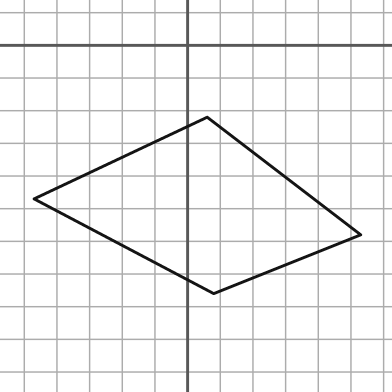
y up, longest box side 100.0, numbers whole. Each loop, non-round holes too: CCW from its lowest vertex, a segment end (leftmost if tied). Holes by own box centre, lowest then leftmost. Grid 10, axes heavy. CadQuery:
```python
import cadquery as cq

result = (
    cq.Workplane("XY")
    .moveTo(8.0, -76.0)
    .lineTo(53.0, -58.0)
    .lineTo(6.0, -22.0)
    .lineTo(-47.0, -47.0)
    .close()
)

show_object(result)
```